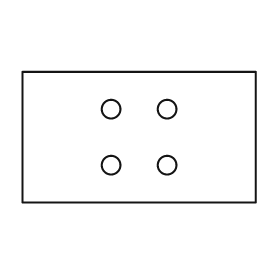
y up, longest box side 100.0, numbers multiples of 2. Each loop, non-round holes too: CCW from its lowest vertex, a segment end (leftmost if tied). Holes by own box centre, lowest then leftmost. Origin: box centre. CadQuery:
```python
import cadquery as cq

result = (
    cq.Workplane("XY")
    .moveTo(-50.0, -28.0)
    .lineTo(50.0, -28.0)
    .lineTo(50.0, 28.0)
    .lineTo(-50.0, 28.0)
    .close()
    .moveTo(-12.0, -12.0)
    .circle(4.0)
    .moveTo(12.0, -12.0)
    .circle(4.0)
    .moveTo(-12.0, 12.0)
    .circle(4.0)
    .moveTo(12.0, 12.0)
    .circle(4.0)
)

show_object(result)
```